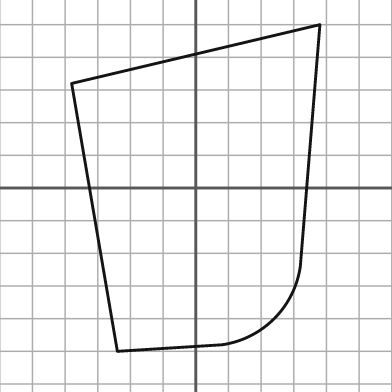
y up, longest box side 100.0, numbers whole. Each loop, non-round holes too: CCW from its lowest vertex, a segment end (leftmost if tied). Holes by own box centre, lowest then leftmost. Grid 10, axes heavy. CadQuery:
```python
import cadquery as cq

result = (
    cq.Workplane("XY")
    .moveTo(-24.0, -50.0)
    .lineTo(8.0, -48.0)
    .threePointArc((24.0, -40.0), (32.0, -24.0))
    .lineTo(38.0, 50.0)
    .lineTo(-38.0, 32.0)
    .close()
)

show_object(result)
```